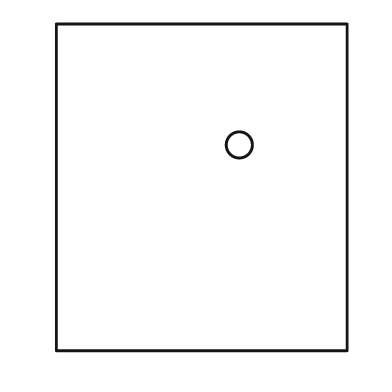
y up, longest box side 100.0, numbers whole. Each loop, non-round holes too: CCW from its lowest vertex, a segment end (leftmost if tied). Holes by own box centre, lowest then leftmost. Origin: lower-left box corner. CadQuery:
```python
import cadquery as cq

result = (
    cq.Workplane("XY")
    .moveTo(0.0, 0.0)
    .lineTo(89.0, 0.0)
    .lineTo(89.0, 100.0)
    .lineTo(0.0, 100.0)
    .close()
    .moveTo(56.0, 63.0)
    .circle(4.0)
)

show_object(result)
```